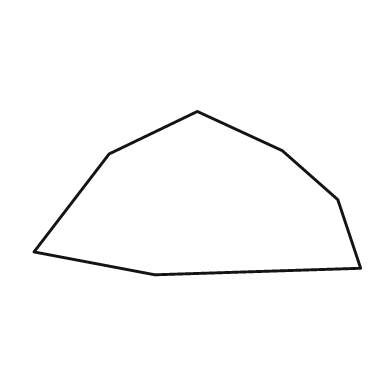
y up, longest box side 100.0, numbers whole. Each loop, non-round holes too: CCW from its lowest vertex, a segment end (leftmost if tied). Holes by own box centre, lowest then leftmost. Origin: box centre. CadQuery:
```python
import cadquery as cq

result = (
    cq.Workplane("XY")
    .moveTo(-13.0, -25.0)
    .lineTo(50.0, -23.0)
    .lineTo(43.0, -2.0)
    .lineTo(26.0, 13.0)
    .lineTo(0.0, 25.0)
    .lineTo(-27.0, 12.0)
    .lineTo(-50.0, -18.0)
    .close()
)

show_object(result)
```